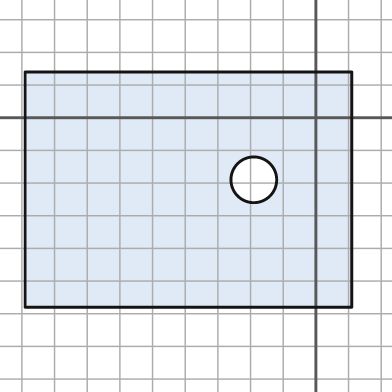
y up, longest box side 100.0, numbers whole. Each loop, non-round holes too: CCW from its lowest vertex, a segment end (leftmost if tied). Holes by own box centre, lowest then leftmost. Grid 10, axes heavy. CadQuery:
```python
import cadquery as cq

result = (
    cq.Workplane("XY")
    .moveTo(-89.0, -58.0)
    .lineTo(11.0, -58.0)
    .lineTo(11.0, 14.0)
    .lineTo(-89.0, 14.0)
    .close()
    .moveTo(-19.0, -19.0)
    .circle(7.0)
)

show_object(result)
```